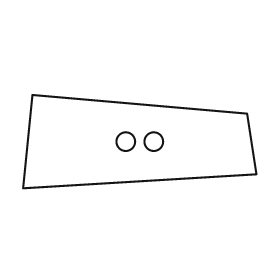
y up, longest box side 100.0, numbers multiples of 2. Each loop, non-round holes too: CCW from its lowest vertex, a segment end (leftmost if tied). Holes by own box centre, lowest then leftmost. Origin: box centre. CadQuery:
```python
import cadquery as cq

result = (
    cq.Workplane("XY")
    .moveTo(-50.0, -20.0)
    .lineTo(50.0, -14.0)
    .lineTo(46.0, 12.0)
    .lineTo(-46.0, 20.0)
    .close()
    .moveTo(-6.0, 0.0)
    .circle(4.0)
    .moveTo(6.0, 0.0)
    .circle(4.0)
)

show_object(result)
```